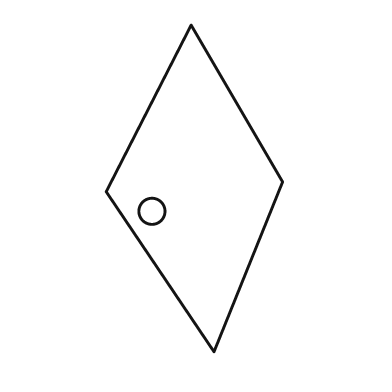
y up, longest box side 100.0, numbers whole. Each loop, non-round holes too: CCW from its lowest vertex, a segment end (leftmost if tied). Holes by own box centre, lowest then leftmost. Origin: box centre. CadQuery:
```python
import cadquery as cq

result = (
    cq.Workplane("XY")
    .moveTo(6.0, -50.0)
    .lineTo(27.0, 2.0)
    .lineTo(-1.0, 50.0)
    .lineTo(-27.0, -1.0)
    .close()
    .moveTo(-13.0, -7.0)
    .circle(4.0)
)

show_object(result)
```